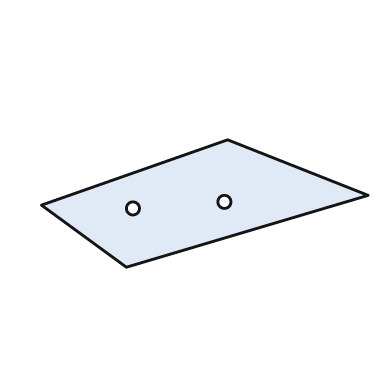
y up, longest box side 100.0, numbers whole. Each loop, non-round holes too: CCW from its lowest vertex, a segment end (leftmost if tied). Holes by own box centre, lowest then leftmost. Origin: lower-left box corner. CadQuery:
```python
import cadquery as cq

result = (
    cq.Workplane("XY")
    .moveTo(26.0, 0.0)
    .lineTo(100.0, 22.0)
    .lineTo(57.0, 39.0)
    .lineTo(0.0, 19.0)
    .close()
    .moveTo(28.0, 18.0)
    .circle(2.0)
    .moveTo(56.0, 20.0)
    .circle(2.0)
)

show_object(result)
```